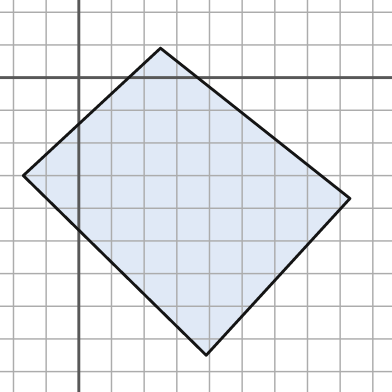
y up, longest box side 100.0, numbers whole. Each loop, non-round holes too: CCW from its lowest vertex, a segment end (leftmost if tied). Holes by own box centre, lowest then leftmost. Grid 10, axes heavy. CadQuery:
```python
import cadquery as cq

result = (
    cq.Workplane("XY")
    .moveTo(39.0, -85.0)
    .lineTo(83.0, -37.0)
    .lineTo(25.0, 9.0)
    .lineTo(-17.0, -30.0)
    .close()
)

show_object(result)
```